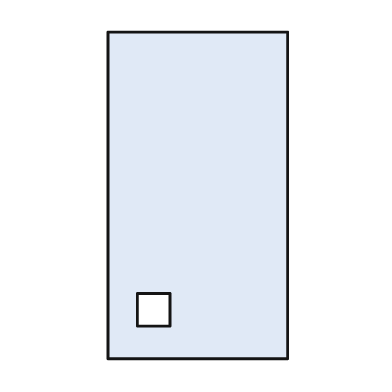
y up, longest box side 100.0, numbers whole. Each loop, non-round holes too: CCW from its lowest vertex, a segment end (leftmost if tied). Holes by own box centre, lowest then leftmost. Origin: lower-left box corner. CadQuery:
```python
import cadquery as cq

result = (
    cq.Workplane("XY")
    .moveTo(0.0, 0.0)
    .lineTo(55.0, 0.0)
    .lineTo(55.0, 100.0)
    .lineTo(0.0, 100.0)
    .close()
    .moveTo(9.0, 10.0)
    .lineTo(19.0, 10.0)
    .lineTo(19.0, 20.0)
    .lineTo(9.0, 20.0)
    .close()
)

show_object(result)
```